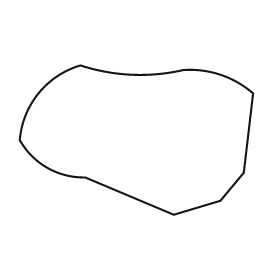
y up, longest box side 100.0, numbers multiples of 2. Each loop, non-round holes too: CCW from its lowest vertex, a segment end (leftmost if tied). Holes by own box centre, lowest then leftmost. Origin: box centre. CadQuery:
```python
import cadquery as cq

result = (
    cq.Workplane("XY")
    .moveTo(16.0, -32.0)
    .lineTo(36.0, -26.0)
    .lineTo(46.0, -14.0)
    .lineTo(50.0, 20.0)
    .threePointArc((36.0, 28.0), (20.0, 30.0))
    .threePointArc((-2.0, 28.0), (-24.0, 32.0))
    .threePointArc((-42.0, 20.0), (-50.0, 0.0))
    .threePointArc((-38.0, -12.0), (-22.0, -16.0))
    .close()
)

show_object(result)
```